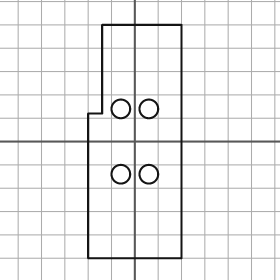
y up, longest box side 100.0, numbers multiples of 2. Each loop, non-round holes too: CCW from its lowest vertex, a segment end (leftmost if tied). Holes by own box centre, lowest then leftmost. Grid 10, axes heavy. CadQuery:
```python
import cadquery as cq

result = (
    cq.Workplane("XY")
    .moveTo(-20.0, -50.0)
    .lineTo(20.0, -50.0)
    .lineTo(20.0, 50.0)
    .lineTo(-14.0, 50.0)
    .lineTo(-14.0, 12.0)
    .lineTo(-20.0, 12.0)
    .close()
    .moveTo(-6.0, -14.0)
    .circle(4.0)
    .moveTo(6.0, -14.0)
    .circle(4.0)
    .moveTo(-6.0, 14.0)
    .circle(4.0)
    .moveTo(6.0, 14.0)
    .circle(4.0)
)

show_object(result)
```